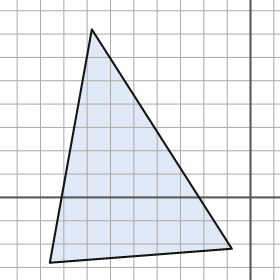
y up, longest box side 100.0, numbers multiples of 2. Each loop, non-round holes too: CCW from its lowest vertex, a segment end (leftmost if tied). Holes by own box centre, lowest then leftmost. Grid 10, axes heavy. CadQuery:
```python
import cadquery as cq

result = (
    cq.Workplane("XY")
    .moveTo(-86.0, -28.0)
    .lineTo(-8.0, -22.0)
    .lineTo(-68.0, 72.0)
    .close()
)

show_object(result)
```